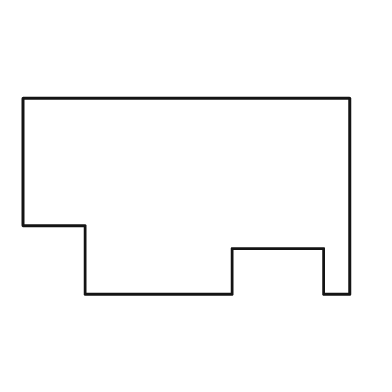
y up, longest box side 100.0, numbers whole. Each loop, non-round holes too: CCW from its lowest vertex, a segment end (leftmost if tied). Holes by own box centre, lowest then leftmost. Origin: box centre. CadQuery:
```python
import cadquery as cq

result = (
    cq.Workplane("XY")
    .moveTo(-31.0, -30.0)
    .lineTo(14.0, -30.0)
    .lineTo(14.0, -16.0)
    .lineTo(42.0, -16.0)
    .lineTo(42.0, -30.0)
    .lineTo(50.0, -30.0)
    .lineTo(50.0, 30.0)
    .lineTo(-50.0, 30.0)
    .lineTo(-50.0, -9.0)
    .lineTo(-31.0, -9.0)
    .close()
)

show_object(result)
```